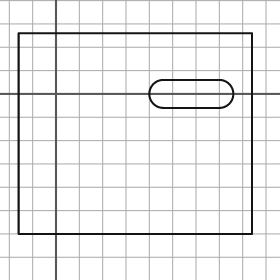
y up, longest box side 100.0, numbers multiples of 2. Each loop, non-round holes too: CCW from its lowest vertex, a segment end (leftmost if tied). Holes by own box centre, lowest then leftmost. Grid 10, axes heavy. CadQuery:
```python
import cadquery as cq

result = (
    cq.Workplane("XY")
    .moveTo(-16.0, -60.0)
    .lineTo(84.0, -60.0)
    .lineTo(84.0, 26.0)
    .lineTo(-16.0, 26.0)
    .close()
    .moveTo(46.0, -6.0)
    .lineTo(70.0, -6.0)
    .threePointArc((76.0, 0.0), (70.0, 6.0))
    .lineTo(46.0, 6.0)
    .threePointArc((40.0, 0.0), (46.0, -6.0))
    .close()
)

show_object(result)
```